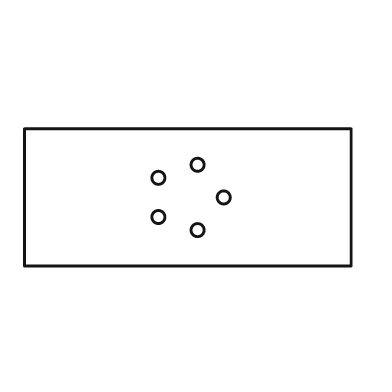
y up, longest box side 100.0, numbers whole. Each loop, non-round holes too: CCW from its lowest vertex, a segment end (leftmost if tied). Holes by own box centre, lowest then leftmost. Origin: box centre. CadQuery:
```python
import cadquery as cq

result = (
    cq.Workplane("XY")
    .moveTo(-50.0, -21.0)
    .lineTo(50.0, -21.0)
    .lineTo(50.0, 21.0)
    .lineTo(-50.0, 21.0)
    .close()
    .moveTo(3.0, -10.0)
    .circle(2.0)
    .moveTo(-9.0, -6.0)
    .circle(2.0)
    .moveTo(11.0, 0.0)
    .circle(2.0)
    .moveTo(-9.0, 6.0)
    .circle(2.0)
    .moveTo(3.0, 10.0)
    .circle(2.0)
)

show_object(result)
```